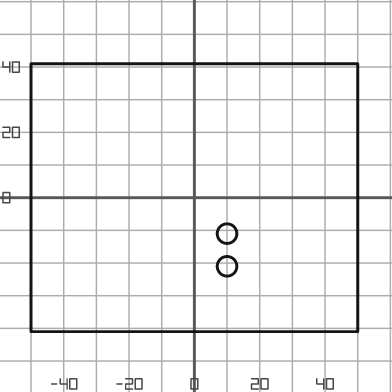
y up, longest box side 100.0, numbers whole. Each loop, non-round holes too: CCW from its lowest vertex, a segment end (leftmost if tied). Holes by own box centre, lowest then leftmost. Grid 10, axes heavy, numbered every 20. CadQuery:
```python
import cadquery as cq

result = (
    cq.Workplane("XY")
    .moveTo(-50.0, -41.0)
    .lineTo(50.0, -41.0)
    .lineTo(50.0, 41.0)
    .lineTo(-50.0, 41.0)
    .close()
    .moveTo(10.0, -21.0)
    .circle(3.0)
    .moveTo(10.0, -11.0)
    .circle(3.0)
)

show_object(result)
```